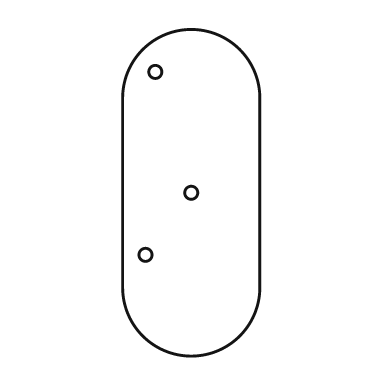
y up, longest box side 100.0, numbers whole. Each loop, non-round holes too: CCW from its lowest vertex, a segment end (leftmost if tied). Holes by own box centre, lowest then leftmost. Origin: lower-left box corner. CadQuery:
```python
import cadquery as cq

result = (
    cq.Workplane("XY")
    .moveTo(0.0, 21.0)
    .threePointArc((21.0, 0.0), (42.0, 21.0))
    .lineTo(42.0, 79.0)
    .threePointArc((21.0, 100.0), (0.0, 79.0))
    .close()
    .moveTo(7.0, 31.0)
    .circle(2.0)
    .moveTo(21.0, 50.0)
    .circle(2.0)
    .moveTo(10.0, 87.0)
    .circle(2.0)
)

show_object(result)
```